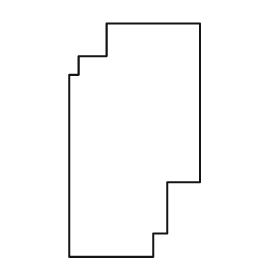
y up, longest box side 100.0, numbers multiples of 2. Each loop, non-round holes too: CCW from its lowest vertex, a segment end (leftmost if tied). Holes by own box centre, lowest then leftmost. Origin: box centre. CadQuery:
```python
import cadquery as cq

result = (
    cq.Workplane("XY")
    .moveTo(-28.0, -50.0)
    .lineTo(8.0, -50.0)
    .lineTo(8.0, -40.0)
    .lineTo(14.0, -40.0)
    .lineTo(14.0, -18.0)
    .lineTo(28.0, -18.0)
    .lineTo(28.0, 50.0)
    .lineTo(-12.0, 50.0)
    .lineTo(-12.0, 36.0)
    .lineTo(-24.0, 36.0)
    .lineTo(-24.0, 28.0)
    .lineTo(-28.0, 28.0)
    .close()
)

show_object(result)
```